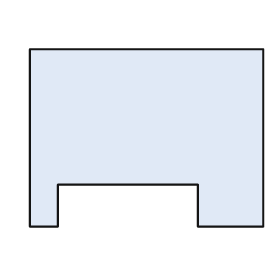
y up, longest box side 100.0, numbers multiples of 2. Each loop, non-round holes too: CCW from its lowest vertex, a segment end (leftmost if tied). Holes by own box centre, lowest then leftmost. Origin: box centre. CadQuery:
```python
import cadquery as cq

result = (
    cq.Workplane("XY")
    .moveTo(-50.0, -38.0)
    .lineTo(-38.0, -38.0)
    .lineTo(-38.0, -20.0)
    .lineTo(22.0, -20.0)
    .lineTo(22.0, -38.0)
    .lineTo(50.0, -38.0)
    .lineTo(50.0, 38.0)
    .lineTo(-50.0, 38.0)
    .close()
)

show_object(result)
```